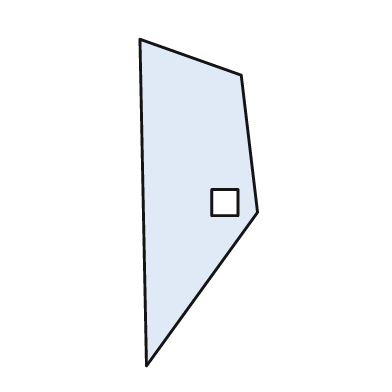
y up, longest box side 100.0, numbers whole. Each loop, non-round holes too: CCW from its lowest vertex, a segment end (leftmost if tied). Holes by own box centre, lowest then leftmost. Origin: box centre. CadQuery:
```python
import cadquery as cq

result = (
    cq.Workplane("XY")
    .moveTo(-16.0, -50.0)
    .lineTo(18.0, -3.0)
    .lineTo(13.0, 39.0)
    .lineTo(-18.0, 50.0)
    .close()
    .moveTo(4.0, -4.0)
    .lineTo(12.0, -4.0)
    .lineTo(12.0, 4.0)
    .lineTo(4.0, 4.0)
    .close()
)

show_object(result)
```